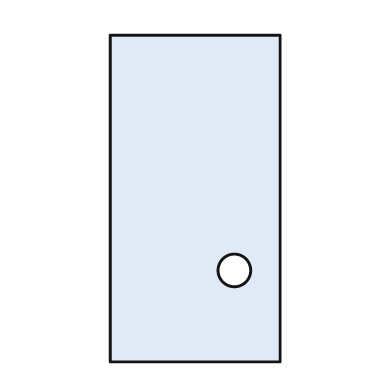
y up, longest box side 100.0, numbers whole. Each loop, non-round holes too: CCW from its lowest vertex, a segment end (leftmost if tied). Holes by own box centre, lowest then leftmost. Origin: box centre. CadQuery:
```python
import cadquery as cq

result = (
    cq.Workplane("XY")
    .moveTo(-26.0, -50.0)
    .lineTo(26.0, -50.0)
    .lineTo(26.0, 50.0)
    .lineTo(-26.0, 50.0)
    .close()
    .moveTo(12.0, -22.0)
    .circle(5.0)
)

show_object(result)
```